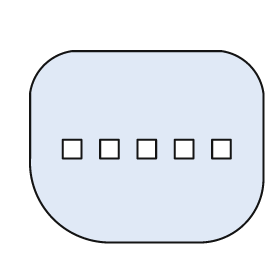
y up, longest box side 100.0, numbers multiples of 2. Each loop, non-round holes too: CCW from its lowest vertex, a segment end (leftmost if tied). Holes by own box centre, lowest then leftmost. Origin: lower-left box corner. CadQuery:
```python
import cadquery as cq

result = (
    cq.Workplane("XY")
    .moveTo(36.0, 0.0)
    .lineTo(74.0, 0.0)
    .threePointArc((92.0, 8.0), (100.0, 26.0))
    .lineTo(100.0, 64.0)
    .threePointArc((94.0, 76.0), (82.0, 82.0))
    .lineTo(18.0, 82.0)
    .threePointArc((6.0, 76.0), (0.0, 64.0))
    .lineTo(0.0, 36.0)
    .threePointArc((10.0, 10.0), (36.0, 0.0))
    .close()
    .moveTo(14.0, 36.0)
    .lineTo(22.0, 36.0)
    .lineTo(22.0, 44.0)
    .lineTo(14.0, 44.0)
    .close()
    .moveTo(30.0, 36.0)
    .lineTo(38.0, 36.0)
    .lineTo(38.0, 44.0)
    .lineTo(30.0, 44.0)
    .close()
    .moveTo(46.0, 36.0)
    .lineTo(54.0, 36.0)
    .lineTo(54.0, 44.0)
    .lineTo(46.0, 44.0)
    .close()
    .moveTo(62.0, 36.0)
    .lineTo(70.0, 36.0)
    .lineTo(70.0, 44.0)
    .lineTo(62.0, 44.0)
    .close()
    .moveTo(78.0, 36.0)
    .lineTo(86.0, 36.0)
    .lineTo(86.0, 44.0)
    .lineTo(78.0, 44.0)
    .close()
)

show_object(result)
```